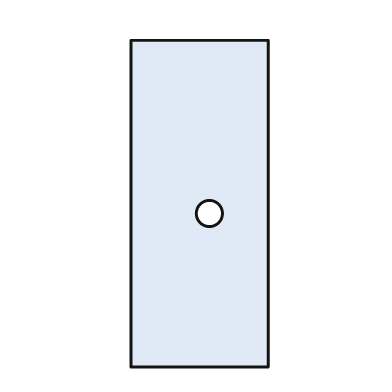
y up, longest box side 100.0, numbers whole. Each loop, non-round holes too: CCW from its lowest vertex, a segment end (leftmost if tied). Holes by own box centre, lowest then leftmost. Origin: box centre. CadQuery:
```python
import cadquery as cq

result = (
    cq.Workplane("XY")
    .moveTo(-21.0, -50.0)
    .lineTo(21.0, -50.0)
    .lineTo(21.0, 50.0)
    .lineTo(-21.0, 50.0)
    .close()
    .moveTo(3.0, -3.0)
    .circle(4.0)
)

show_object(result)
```